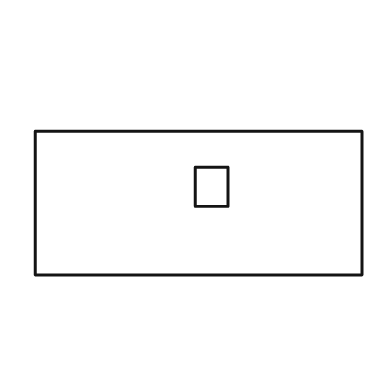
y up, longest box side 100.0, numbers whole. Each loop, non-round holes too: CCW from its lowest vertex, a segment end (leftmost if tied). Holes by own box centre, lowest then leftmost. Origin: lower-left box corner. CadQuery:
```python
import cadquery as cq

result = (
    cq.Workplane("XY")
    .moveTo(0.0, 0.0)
    .lineTo(100.0, 0.0)
    .lineTo(100.0, 44.0)
    .lineTo(0.0, 44.0)
    .close()
    .moveTo(49.0, 21.0)
    .lineTo(59.0, 21.0)
    .lineTo(59.0, 33.0)
    .lineTo(49.0, 33.0)
    .close()
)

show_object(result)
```